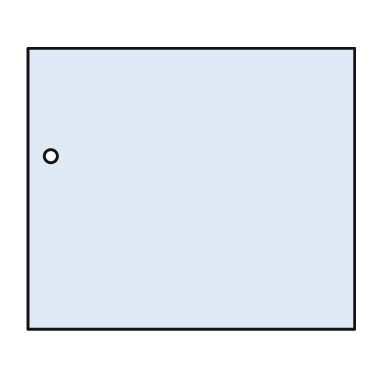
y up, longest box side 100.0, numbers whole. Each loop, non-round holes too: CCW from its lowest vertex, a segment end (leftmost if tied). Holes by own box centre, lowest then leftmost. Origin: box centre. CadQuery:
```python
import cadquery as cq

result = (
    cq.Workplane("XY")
    .moveTo(-50.0, -43.0)
    .lineTo(50.0, -43.0)
    .lineTo(50.0, 43.0)
    .lineTo(-50.0, 43.0)
    .close()
    .moveTo(-43.0, 10.0)
    .circle(2.0)
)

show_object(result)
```